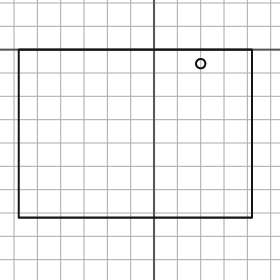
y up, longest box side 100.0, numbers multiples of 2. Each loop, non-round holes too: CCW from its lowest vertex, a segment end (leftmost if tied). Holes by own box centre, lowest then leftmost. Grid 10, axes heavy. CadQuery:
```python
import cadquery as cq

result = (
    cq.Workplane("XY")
    .moveTo(-58.0, -72.0)
    .lineTo(42.0, -72.0)
    .lineTo(42.0, 0.0)
    .lineTo(-58.0, 0.0)
    .close()
    .moveTo(20.0, -6.0)
    .circle(2.0)
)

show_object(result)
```